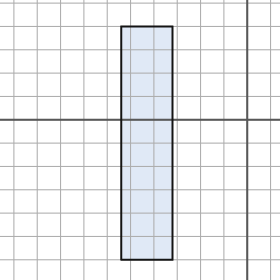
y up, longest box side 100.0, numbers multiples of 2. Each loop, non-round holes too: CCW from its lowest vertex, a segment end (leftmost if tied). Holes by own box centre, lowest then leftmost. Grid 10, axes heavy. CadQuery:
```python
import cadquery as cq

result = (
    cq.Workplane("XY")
    .moveTo(-54.0, -60.0)
    .lineTo(-32.0, -60.0)
    .lineTo(-32.0, 40.0)
    .lineTo(-54.0, 40.0)
    .close()
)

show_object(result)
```